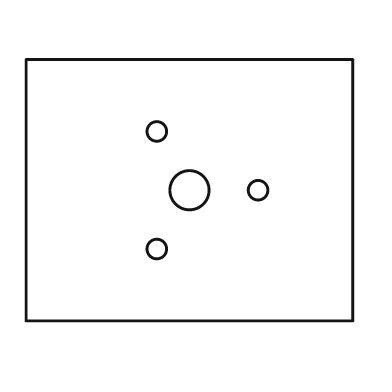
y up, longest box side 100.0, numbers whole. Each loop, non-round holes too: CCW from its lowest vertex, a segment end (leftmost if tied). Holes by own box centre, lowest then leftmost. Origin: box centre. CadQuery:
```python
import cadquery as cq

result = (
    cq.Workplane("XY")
    .moveTo(-50.0, -40.0)
    .lineTo(50.0, -40.0)
    .lineTo(50.0, 40.0)
    .lineTo(-50.0, 40.0)
    .close()
    .moveTo(-10.0, -18.0)
    .circle(3.0)
    .moveTo(0.0, 0.0)
    .circle(6.0)
    .moveTo(21.0, 0.0)
    .circle(3.0)
    .moveTo(-10.0, 18.0)
    .circle(3.0)
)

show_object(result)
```